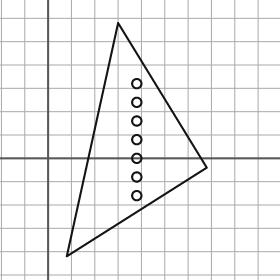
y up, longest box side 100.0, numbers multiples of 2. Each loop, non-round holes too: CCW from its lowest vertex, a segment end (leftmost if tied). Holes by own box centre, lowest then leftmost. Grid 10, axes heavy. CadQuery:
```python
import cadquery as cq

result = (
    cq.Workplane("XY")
    .moveTo(8.0, -42.0)
    .lineTo(68.0, -4.0)
    .lineTo(30.0, 58.0)
    .close()
    .moveTo(38.0, -16.0)
    .circle(2.0)
    .moveTo(38.0, -8.0)
    .circle(2.0)
    .moveTo(38.0, 0.0)
    .circle(2.0)
    .moveTo(38.0, 8.0)
    .circle(2.0)
    .moveTo(38.0, 16.0)
    .circle(2.0)
    .moveTo(38.0, 24.0)
    .circle(2.0)
    .moveTo(38.0, 32.0)
    .circle(2.0)
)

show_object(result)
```